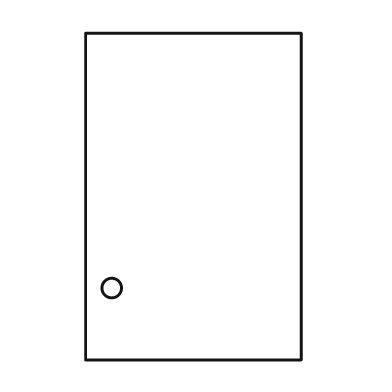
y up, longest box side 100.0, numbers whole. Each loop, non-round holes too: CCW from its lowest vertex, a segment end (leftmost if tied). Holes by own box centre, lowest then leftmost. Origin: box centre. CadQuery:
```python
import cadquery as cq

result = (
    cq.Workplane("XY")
    .moveTo(-33.0, -50.0)
    .lineTo(33.0, -50.0)
    .lineTo(33.0, 50.0)
    .lineTo(-33.0, 50.0)
    .close()
    .moveTo(-25.0, -28.0)
    .circle(3.0)
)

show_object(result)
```